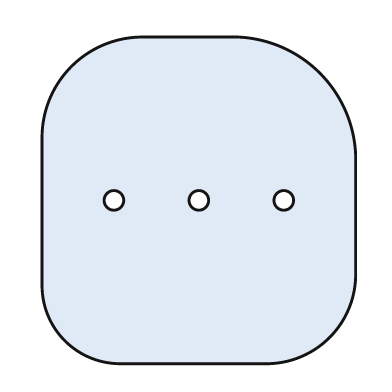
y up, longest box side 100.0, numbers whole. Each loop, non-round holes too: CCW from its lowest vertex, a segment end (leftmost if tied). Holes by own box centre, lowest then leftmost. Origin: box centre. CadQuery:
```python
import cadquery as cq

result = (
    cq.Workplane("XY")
    .moveTo(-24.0, -50.0)
    .lineTo(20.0, -50.0)
    .threePointArc((40.0, -42.0), (48.0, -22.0))
    .lineTo(48.0, 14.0)
    .threePointArc((37.0, 39.0), (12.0, 50.0))
    .lineTo(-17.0, 50.0)
    .threePointArc((-39.0, 41.0), (-48.0, 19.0))
    .lineTo(-48.0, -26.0)
    .threePointArc((-41.0, -43.0), (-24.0, -50.0))
    .close()
    .moveTo(-26.0, 0.0)
    .circle(3.0)
    .moveTo(0.0, 0.0)
    .circle(3.0)
    .moveTo(26.0, 0.0)
    .circle(3.0)
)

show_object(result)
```